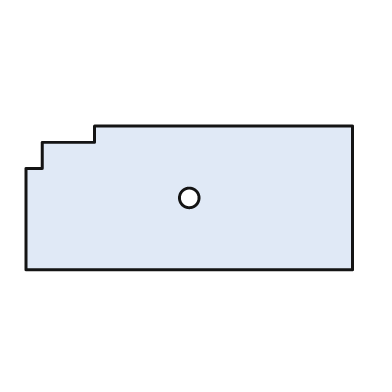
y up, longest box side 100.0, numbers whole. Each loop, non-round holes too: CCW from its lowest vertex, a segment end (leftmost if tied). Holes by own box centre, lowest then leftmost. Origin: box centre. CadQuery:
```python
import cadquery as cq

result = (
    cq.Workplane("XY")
    .moveTo(-50.0, -22.0)
    .lineTo(50.0, -22.0)
    .lineTo(50.0, 22.0)
    .lineTo(-29.0, 22.0)
    .lineTo(-29.0, 17.0)
    .lineTo(-45.0, 17.0)
    .lineTo(-45.0, 9.0)
    .lineTo(-50.0, 9.0)
    .close()
    .moveTo(0.0, 0.0)
    .circle(3.0)
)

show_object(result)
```